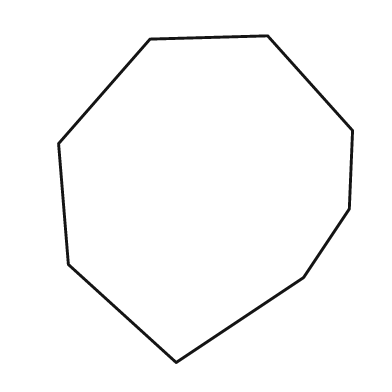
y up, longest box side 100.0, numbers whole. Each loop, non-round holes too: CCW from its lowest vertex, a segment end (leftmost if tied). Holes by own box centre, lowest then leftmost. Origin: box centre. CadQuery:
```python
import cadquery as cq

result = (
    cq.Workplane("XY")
    .moveTo(-9.0, -50.0)
    .lineTo(30.0, -24.0)
    .lineTo(44.0, -3.0)
    .lineTo(45.0, 21.0)
    .lineTo(19.0, 50.0)
    .lineTo(-17.0, 49.0)
    .lineTo(-45.0, 17.0)
    .lineTo(-42.0, -20.0)
    .close()
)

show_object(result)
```